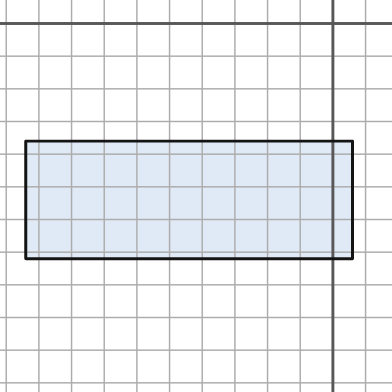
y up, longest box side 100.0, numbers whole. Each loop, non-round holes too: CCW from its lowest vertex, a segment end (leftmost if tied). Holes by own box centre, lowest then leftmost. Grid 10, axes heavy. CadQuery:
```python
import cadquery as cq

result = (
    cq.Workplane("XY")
    .moveTo(-94.0, -72.0)
    .lineTo(6.0, -72.0)
    .lineTo(6.0, -36.0)
    .lineTo(-94.0, -36.0)
    .close()
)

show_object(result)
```